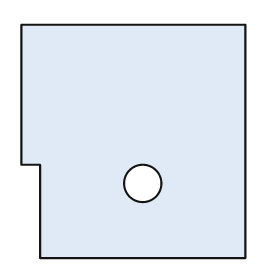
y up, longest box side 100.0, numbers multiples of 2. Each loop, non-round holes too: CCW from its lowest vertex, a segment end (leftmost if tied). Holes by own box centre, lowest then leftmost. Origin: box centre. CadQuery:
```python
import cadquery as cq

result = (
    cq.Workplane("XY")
    .moveTo(-40.0, -50.0)
    .lineTo(48.0, -50.0)
    .lineTo(48.0, 50.0)
    .lineTo(-48.0, 50.0)
    .lineTo(-48.0, -10.0)
    .lineTo(-40.0, -10.0)
    .close()
    .moveTo(4.0, -18.0)
    .circle(8.0)
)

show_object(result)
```